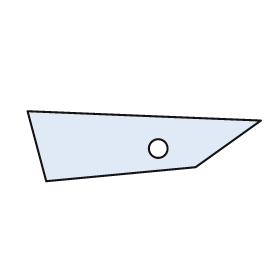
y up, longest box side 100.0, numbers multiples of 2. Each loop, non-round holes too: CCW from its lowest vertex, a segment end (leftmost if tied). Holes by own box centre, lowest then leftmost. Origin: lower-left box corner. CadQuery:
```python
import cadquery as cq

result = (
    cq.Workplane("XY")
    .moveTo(8.0, 0.0)
    .lineTo(72.0, 6.0)
    .lineTo(100.0, 26.0)
    .lineTo(0.0, 30.0)
    .close()
    .moveTo(56.0, 14.0)
    .circle(4.0)
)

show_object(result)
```